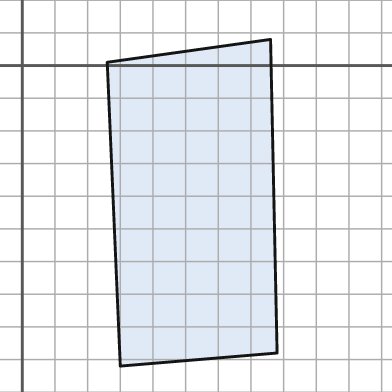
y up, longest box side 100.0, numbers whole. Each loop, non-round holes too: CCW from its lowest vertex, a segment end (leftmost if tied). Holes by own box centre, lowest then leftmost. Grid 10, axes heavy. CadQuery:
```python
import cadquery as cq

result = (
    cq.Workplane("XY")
    .moveTo(30.0, -92.0)
    .lineTo(78.0, -88.0)
    .lineTo(76.0, 8.0)
    .lineTo(26.0, 1.0)
    .close()
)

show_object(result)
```